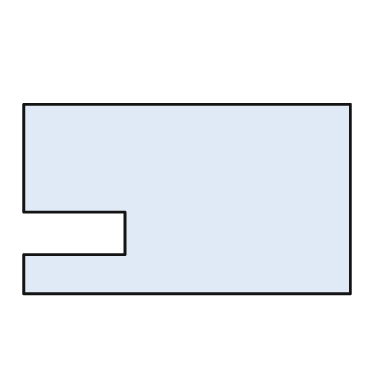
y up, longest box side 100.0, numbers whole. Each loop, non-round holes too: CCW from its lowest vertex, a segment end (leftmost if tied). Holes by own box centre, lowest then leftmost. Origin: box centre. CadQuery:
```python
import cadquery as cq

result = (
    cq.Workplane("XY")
    .moveTo(-50.0, -29.0)
    .lineTo(50.0, -29.0)
    .lineTo(50.0, 29.0)
    .lineTo(-50.0, 29.0)
    .lineTo(-50.0, -4.0)
    .lineTo(-19.0, -4.0)
    .lineTo(-19.0, -17.0)
    .lineTo(-50.0, -17.0)
    .close()
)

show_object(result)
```